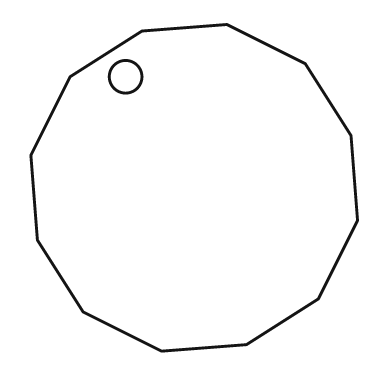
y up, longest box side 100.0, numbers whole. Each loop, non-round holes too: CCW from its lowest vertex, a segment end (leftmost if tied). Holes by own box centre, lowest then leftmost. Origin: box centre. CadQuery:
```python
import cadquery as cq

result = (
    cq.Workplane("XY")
    .moveTo(-10.0, -50.0)
    .lineTo(16.0, -48.0)
    .lineTo(38.0, -34.0)
    .lineTo(50.0, -10.0)
    .lineTo(48.0, 16.0)
    .lineTo(34.0, 38.0)
    .lineTo(10.0, 50.0)
    .lineTo(-16.0, 48.0)
    .lineTo(-38.0, 34.0)
    .lineTo(-50.0, 10.0)
    .lineTo(-48.0, -16.0)
    .lineTo(-34.0, -38.0)
    .close()
    .moveTo(-21.0, 34.0)
    .circle(5.0)
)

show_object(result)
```